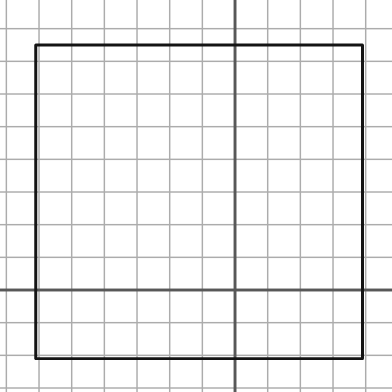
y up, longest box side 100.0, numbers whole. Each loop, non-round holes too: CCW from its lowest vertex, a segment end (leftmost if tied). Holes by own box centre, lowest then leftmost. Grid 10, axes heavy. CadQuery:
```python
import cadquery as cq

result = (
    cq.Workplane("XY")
    .moveTo(-61.0, -21.0)
    .lineTo(39.0, -21.0)
    .lineTo(39.0, 75.0)
    .lineTo(-61.0, 75.0)
    .close()
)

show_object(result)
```